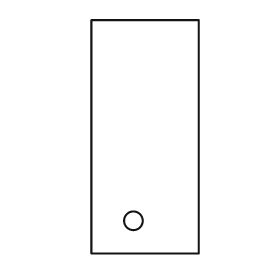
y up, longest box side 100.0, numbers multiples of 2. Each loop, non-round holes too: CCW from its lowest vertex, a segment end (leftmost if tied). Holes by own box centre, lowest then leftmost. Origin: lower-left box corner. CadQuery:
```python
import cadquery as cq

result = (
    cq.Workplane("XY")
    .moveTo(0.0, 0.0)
    .lineTo(46.0, 0.0)
    .lineTo(46.0, 100.0)
    .lineTo(0.0, 100.0)
    .close()
    .moveTo(18.0, 14.0)
    .circle(4.0)
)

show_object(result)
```